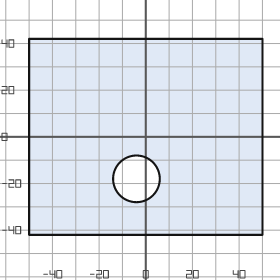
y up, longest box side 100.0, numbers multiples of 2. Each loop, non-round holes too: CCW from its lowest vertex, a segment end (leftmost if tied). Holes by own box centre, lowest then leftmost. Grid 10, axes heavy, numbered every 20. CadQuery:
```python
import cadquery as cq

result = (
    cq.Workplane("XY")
    .moveTo(-50.0, -42.0)
    .lineTo(50.0, -42.0)
    .lineTo(50.0, 42.0)
    .lineTo(-50.0, 42.0)
    .close()
    .moveTo(-4.0, -18.0)
    .circle(10.0)
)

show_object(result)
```